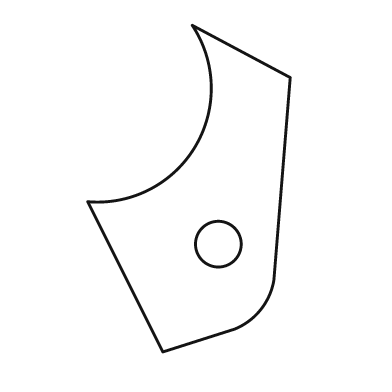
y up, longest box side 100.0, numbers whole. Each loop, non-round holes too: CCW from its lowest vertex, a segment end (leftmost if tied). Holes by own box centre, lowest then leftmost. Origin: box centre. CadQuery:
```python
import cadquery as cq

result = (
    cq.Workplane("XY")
    .moveTo(-8.0, -50.0)
    .lineTo(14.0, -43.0)
    .threePointArc((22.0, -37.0), (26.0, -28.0))
    .lineTo(31.0, 34.0)
    .lineTo(1.0, 50.0)
    .threePointArc((2.0, 13.0), (-31.0, -4.0))
    .close()
    .moveTo(9.0, -17.0)
    .circle(7.0)
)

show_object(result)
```